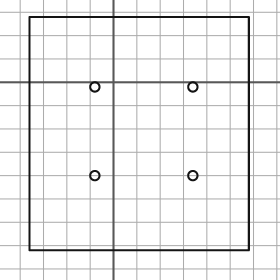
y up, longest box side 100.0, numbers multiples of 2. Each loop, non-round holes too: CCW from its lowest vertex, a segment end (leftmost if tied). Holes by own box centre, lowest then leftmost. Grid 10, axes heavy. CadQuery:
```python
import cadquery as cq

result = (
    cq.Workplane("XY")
    .moveTo(-36.0, -72.0)
    .lineTo(58.0, -72.0)
    .lineTo(58.0, 28.0)
    .lineTo(-36.0, 28.0)
    .close()
    .moveTo(-8.0, -40.0)
    .circle(2.0)
    .moveTo(34.0, -40.0)
    .circle(2.0)
    .moveTo(-8.0, -2.0)
    .circle(2.0)
    .moveTo(34.0, -2.0)
    .circle(2.0)
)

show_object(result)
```